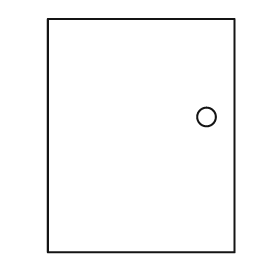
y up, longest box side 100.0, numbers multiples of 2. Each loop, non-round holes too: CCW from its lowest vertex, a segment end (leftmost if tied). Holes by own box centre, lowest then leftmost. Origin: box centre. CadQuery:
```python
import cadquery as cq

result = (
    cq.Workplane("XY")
    .moveTo(-40.0, -50.0)
    .lineTo(40.0, -50.0)
    .lineTo(40.0, 50.0)
    .lineTo(-40.0, 50.0)
    .close()
    .moveTo(28.0, 8.0)
    .circle(4.0)
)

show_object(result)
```